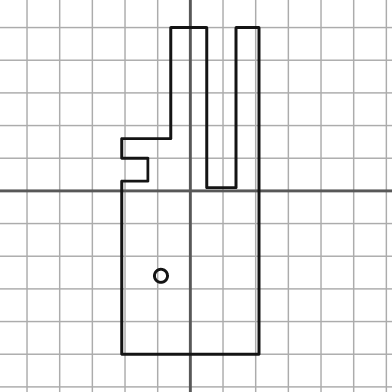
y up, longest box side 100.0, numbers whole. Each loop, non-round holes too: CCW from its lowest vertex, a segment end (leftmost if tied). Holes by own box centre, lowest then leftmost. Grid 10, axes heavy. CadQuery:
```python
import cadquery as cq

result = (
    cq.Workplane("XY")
    .moveTo(-21.0, -50.0)
    .lineTo(21.0, -50.0)
    .lineTo(21.0, 50.0)
    .lineTo(14.0, 50.0)
    .lineTo(14.0, 1.0)
    .lineTo(5.0, 1.0)
    .lineTo(5.0, 50.0)
    .lineTo(-6.0, 50.0)
    .lineTo(-6.0, 16.0)
    .lineTo(-21.0, 16.0)
    .lineTo(-21.0, 10.0)
    .lineTo(-13.0, 10.0)
    .lineTo(-13.0, 3.0)
    .lineTo(-21.0, 3.0)
    .close()
    .moveTo(-9.0, -26.0)
    .circle(2.0)
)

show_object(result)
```